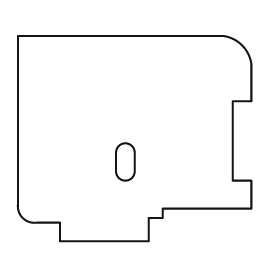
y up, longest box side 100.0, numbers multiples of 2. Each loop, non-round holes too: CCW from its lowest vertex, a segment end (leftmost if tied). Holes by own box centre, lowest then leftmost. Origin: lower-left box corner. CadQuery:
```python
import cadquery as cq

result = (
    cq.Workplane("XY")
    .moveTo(18.0, 0.0)
    .lineTo(56.0, 0.0)
    .lineTo(56.0, 10.0)
    .lineTo(62.0, 10.0)
    .lineTo(62.0, 14.0)
    .lineTo(100.0, 14.0)
    .lineTo(100.0, 26.0)
    .lineTo(92.0, 26.0)
    .lineTo(92.0, 60.0)
    .lineTo(100.0, 60.0)
    .lineTo(100.0, 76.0)
    .threePointArc((96.0, 84.0), (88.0, 88.0))
    .lineTo(0.0, 88.0)
    .lineTo(0.0, 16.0)
    .threePointArc((2.0, 10.0), (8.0, 8.0))
    .lineTo(18.0, 8.0)
    .close()
    .moveTo(42.0, 30.0)
    .threePointArc((46.0, 26.0), (50.0, 30.0))
    .lineTo(50.0, 38.0)
    .threePointArc((46.0, 42.0), (42.0, 38.0))
    .close()
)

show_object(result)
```